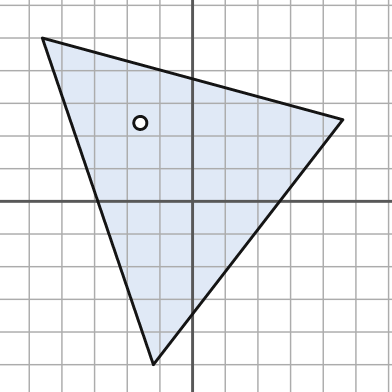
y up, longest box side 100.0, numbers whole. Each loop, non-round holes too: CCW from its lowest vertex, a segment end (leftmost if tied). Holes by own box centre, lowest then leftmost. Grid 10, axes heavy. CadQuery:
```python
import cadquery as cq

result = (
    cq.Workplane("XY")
    .moveTo(-12.0, -50.0)
    .lineTo(46.0, 25.0)
    .lineTo(-46.0, 50.0)
    .close()
    .moveTo(-16.0, 24.0)
    .circle(2.0)
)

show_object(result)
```